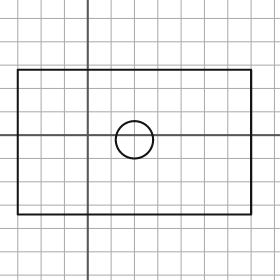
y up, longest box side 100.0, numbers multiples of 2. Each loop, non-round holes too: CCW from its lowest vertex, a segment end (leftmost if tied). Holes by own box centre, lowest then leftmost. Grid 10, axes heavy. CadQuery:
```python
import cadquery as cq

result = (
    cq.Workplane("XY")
    .moveTo(-30.0, -34.0)
    .lineTo(70.0, -34.0)
    .lineTo(70.0, 28.0)
    .lineTo(-30.0, 28.0)
    .close()
    .moveTo(20.0, -2.0)
    .circle(8.0)
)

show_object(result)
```